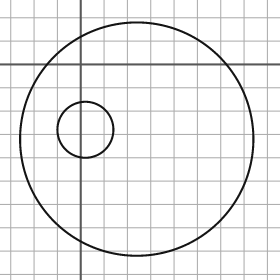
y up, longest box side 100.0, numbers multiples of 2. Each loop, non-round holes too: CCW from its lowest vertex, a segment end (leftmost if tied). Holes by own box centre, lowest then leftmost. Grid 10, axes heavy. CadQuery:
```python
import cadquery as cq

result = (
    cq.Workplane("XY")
    .moveTo(24.0, -32.0)
    .circle(50.0)
    .moveTo(2.0, -28.0)
    .circle(12.0)
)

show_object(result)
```